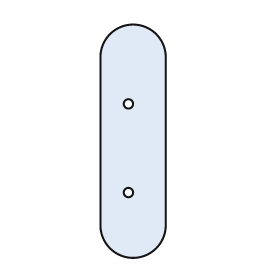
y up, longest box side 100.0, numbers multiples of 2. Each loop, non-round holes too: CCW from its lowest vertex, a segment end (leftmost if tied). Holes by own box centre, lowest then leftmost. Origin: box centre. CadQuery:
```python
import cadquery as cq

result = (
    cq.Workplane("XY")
    .moveTo(-14.0, -36.0)
    .threePointArc((0.0, -50.0), (14.0, -36.0))
    .lineTo(14.0, 36.0)
    .threePointArc((0.0, 50.0), (-14.0, 36.0))
    .close()
    .moveTo(-2.0, -22.0)
    .circle(2.0)
    .moveTo(-2.0, 16.0)
    .circle(2.0)
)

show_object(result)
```